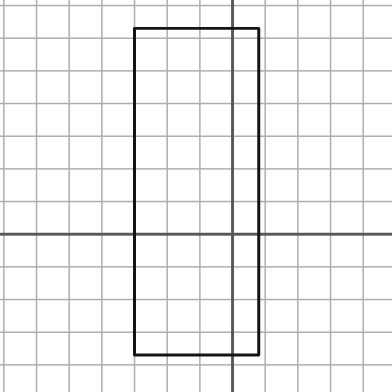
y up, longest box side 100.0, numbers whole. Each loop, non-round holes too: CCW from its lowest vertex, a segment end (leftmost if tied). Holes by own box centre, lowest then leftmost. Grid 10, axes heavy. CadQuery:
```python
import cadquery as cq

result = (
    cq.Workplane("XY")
    .moveTo(-30.0, -37.0)
    .lineTo(8.0, -37.0)
    .lineTo(8.0, 63.0)
    .lineTo(-30.0, 63.0)
    .close()
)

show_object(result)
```